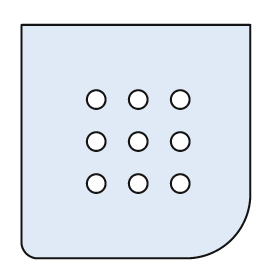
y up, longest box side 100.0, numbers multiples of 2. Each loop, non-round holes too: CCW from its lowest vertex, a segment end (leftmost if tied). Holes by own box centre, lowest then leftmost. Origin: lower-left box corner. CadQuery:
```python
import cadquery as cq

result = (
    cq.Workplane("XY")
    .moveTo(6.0, 0.0)
    .lineTo(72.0, 0.0)
    .threePointArc((90.0, 8.0), (98.0, 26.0))
    .lineTo(98.0, 100.0)
    .lineTo(0.0, 100.0)
    .lineTo(0.0, 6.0)
    .threePointArc((2.0, 2.0), (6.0, 0.0))
    .close()
    .moveTo(32.0, 32.0)
    .circle(4.0)
    .moveTo(50.0, 32.0)
    .circle(4.0)
    .moveTo(68.0, 32.0)
    .circle(4.0)
    .moveTo(32.0, 50.0)
    .circle(4.0)
    .moveTo(50.0, 50.0)
    .circle(4.0)
    .moveTo(68.0, 50.0)
    .circle(4.0)
    .moveTo(32.0, 68.0)
    .circle(4.0)
    .moveTo(50.0, 68.0)
    .circle(4.0)
    .moveTo(68.0, 68.0)
    .circle(4.0)
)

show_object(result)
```